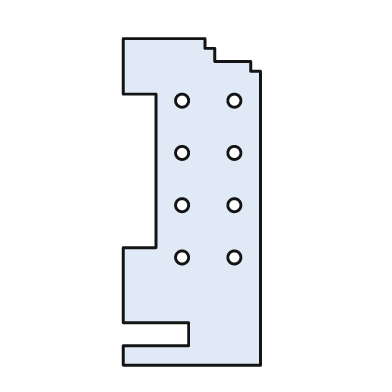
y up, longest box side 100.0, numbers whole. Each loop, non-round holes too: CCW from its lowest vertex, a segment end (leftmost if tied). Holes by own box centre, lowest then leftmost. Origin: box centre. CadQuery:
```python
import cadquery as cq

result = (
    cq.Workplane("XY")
    .moveTo(-21.0, -50.0)
    .lineTo(21.0, -50.0)
    .lineTo(21.0, 40.0)
    .lineTo(18.0, 40.0)
    .lineTo(18.0, 43.0)
    .lineTo(7.0, 43.0)
    .lineTo(7.0, 47.0)
    .lineTo(4.0, 47.0)
    .lineTo(4.0, 50.0)
    .lineTo(-21.0, 50.0)
    .lineTo(-21.0, 33.0)
    .lineTo(-11.0, 33.0)
    .lineTo(-11.0, -14.0)
    .lineTo(-21.0, -14.0)
    .lineTo(-21.0, -37.0)
    .lineTo(-1.0, -37.0)
    .lineTo(-1.0, -44.0)
    .lineTo(-21.0, -44.0)
    .close()
    .moveTo(-3.0, -17.0)
    .circle(2.0)
    .moveTo(13.0, -17.0)
    .circle(2.0)
    .moveTo(-3.0, -1.0)
    .circle(2.0)
    .moveTo(13.0, -1.0)
    .circle(2.0)
    .moveTo(-3.0, 15.0)
    .circle(2.0)
    .moveTo(13.0, 15.0)
    .circle(2.0)
    .moveTo(-3.0, 31.0)
    .circle(2.0)
    .moveTo(13.0, 31.0)
    .circle(2.0)
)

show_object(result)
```